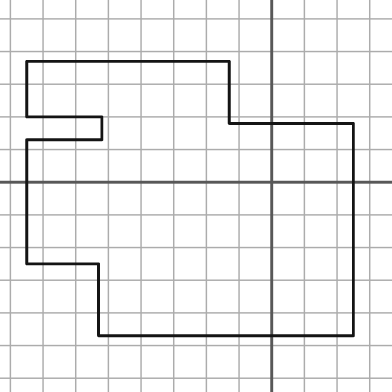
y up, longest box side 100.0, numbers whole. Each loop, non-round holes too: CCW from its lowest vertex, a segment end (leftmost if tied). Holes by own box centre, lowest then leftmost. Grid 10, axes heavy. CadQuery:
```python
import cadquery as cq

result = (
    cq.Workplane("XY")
    .moveTo(-53.0, -47.0)
    .lineTo(25.0, -47.0)
    .lineTo(25.0, 18.0)
    .lineTo(-13.0, 18.0)
    .lineTo(-13.0, 37.0)
    .lineTo(-75.0, 37.0)
    .lineTo(-75.0, 20.0)
    .lineTo(-52.0, 20.0)
    .lineTo(-52.0, 13.0)
    .lineTo(-75.0, 13.0)
    .lineTo(-75.0, -25.0)
    .lineTo(-53.0, -25.0)
    .close()
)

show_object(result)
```